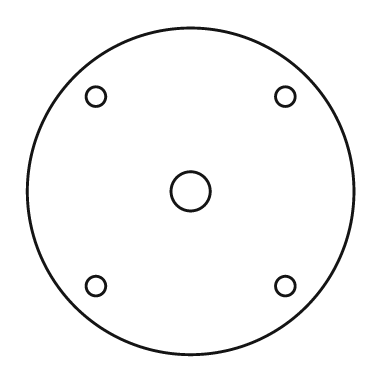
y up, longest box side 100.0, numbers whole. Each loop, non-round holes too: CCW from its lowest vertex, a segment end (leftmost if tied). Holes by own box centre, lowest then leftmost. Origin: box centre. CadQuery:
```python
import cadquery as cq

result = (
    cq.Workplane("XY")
    .moveTo(0.0, 0.0)
    .circle(50.0)
    .moveTo(-29.0, -29.0)
    .circle(3.0)
    .moveTo(29.0, -29.0)
    .circle(3.0)
    .moveTo(0.0, 0.0)
    .circle(6.0)
    .moveTo(-29.0, 29.0)
    .circle(3.0)
    .moveTo(29.0, 29.0)
    .circle(3.0)
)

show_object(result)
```